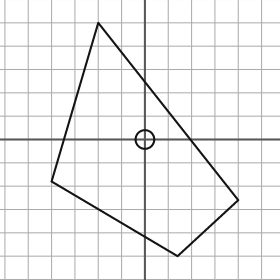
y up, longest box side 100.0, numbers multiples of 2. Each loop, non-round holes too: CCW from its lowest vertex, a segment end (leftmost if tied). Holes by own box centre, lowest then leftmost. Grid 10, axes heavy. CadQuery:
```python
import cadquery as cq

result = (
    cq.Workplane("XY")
    .moveTo(14.0, -50.0)
    .lineTo(40.0, -26.0)
    .lineTo(-20.0, 50.0)
    .lineTo(-40.0, -18.0)
    .close()
    .moveTo(0.0, 0.0)
    .circle(4.0)
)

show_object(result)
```